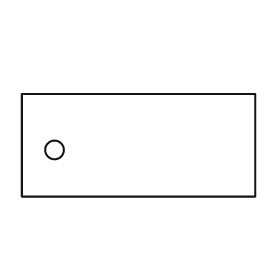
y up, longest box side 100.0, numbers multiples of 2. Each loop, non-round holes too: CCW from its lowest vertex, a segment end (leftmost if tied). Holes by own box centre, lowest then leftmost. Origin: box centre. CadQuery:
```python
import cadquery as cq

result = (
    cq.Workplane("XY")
    .moveTo(-50.0, -22.0)
    .lineTo(50.0, -22.0)
    .lineTo(50.0, 22.0)
    .lineTo(-50.0, 22.0)
    .close()
    .moveTo(-36.0, -2.0)
    .circle(4.0)
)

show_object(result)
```